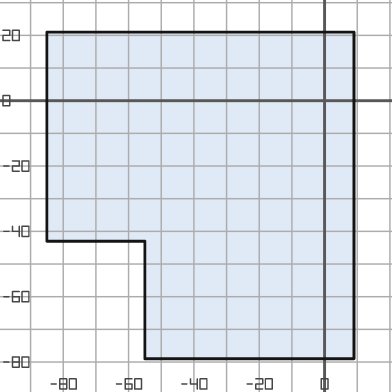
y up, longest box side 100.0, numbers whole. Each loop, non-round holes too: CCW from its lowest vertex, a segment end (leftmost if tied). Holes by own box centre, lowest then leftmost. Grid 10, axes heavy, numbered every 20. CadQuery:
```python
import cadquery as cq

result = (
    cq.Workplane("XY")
    .moveTo(-55.0, -79.0)
    .lineTo(9.0, -79.0)
    .lineTo(9.0, 21.0)
    .lineTo(-85.0, 21.0)
    .lineTo(-85.0, -43.0)
    .lineTo(-55.0, -43.0)
    .close()
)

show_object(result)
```